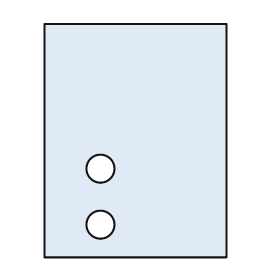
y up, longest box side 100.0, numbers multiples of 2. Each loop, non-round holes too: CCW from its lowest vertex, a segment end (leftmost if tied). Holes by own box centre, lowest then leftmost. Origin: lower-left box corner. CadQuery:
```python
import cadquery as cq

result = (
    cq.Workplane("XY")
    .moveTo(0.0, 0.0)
    .lineTo(78.0, 0.0)
    .lineTo(78.0, 100.0)
    .lineTo(0.0, 100.0)
    .close()
    .moveTo(24.0, 14.0)
    .circle(6.0)
    .moveTo(24.0, 38.0)
    .circle(6.0)
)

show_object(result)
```